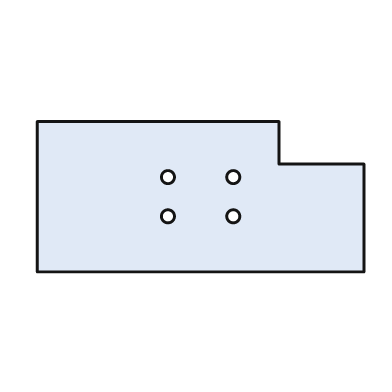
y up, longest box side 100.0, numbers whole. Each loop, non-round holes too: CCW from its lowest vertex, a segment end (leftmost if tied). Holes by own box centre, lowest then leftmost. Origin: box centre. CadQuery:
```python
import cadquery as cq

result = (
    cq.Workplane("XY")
    .moveTo(-50.0, -23.0)
    .lineTo(50.0, -23.0)
    .lineTo(50.0, 10.0)
    .lineTo(24.0, 10.0)
    .lineTo(24.0, 23.0)
    .lineTo(-50.0, 23.0)
    .close()
    .moveTo(-10.0, -6.0)
    .circle(2.0)
    .moveTo(10.0, -6.0)
    .circle(2.0)
    .moveTo(-10.0, 6.0)
    .circle(2.0)
    .moveTo(10.0, 6.0)
    .circle(2.0)
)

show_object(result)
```